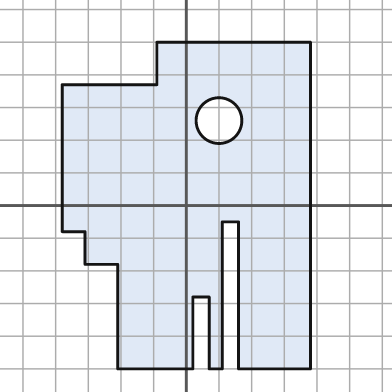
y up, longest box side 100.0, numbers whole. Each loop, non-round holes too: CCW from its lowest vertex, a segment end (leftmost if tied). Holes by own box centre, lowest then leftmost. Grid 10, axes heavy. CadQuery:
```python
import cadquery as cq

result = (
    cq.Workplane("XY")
    .moveTo(-21.0, -50.0)
    .lineTo(2.0, -50.0)
    .lineTo(2.0, -28.0)
    .lineTo(7.0, -28.0)
    .lineTo(7.0, -50.0)
    .lineTo(11.0, -50.0)
    .lineTo(11.0, -5.0)
    .lineTo(16.0, -5.0)
    .lineTo(16.0, -50.0)
    .lineTo(38.0, -50.0)
    .lineTo(38.0, 50.0)
    .lineTo(-9.0, 50.0)
    .lineTo(-9.0, 37.0)
    .lineTo(-38.0, 37.0)
    .lineTo(-38.0, -8.0)
    .lineTo(-31.0, -8.0)
    .lineTo(-31.0, -18.0)
    .lineTo(-21.0, -18.0)
    .close()
    .moveTo(10.0, 26.0)
    .circle(7.0)
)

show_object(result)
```